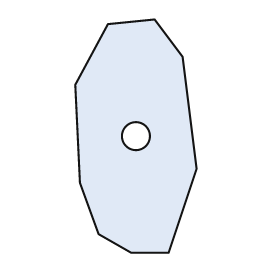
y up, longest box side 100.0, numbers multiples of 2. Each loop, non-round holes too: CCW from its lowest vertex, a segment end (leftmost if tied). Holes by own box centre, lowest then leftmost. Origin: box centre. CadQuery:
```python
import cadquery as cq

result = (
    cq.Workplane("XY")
    .moveTo(-2.0, -50.0)
    .lineTo(14.0, -50.0)
    .lineTo(26.0, -14.0)
    .lineTo(20.0, 34.0)
    .lineTo(8.0, 50.0)
    .lineTo(-12.0, 48.0)
    .lineTo(-26.0, 22.0)
    .lineTo(-24.0, -20.0)
    .lineTo(-16.0, -42.0)
    .close()
    .moveTo(0.0, 0.0)
    .circle(6.0)
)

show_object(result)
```